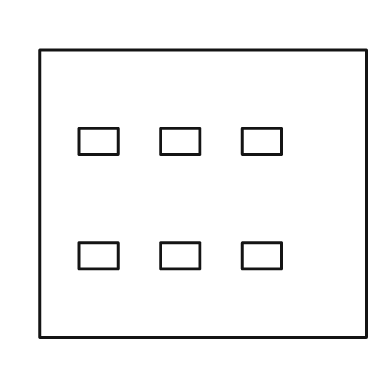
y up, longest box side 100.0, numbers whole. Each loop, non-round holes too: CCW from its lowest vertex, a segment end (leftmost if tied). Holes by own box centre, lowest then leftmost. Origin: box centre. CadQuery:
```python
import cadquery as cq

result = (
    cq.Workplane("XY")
    .moveTo(-50.0, -44.0)
    .lineTo(50.0, -44.0)
    .lineTo(50.0, 44.0)
    .lineTo(-50.0, 44.0)
    .close()
    .moveTo(-38.0, -23.0)
    .lineTo(-26.0, -23.0)
    .lineTo(-26.0, -15.0)
    .lineTo(-38.0, -15.0)
    .close()
    .moveTo(-13.0, -23.0)
    .lineTo(-1.0, -23.0)
    .lineTo(-1.0, -15.0)
    .lineTo(-13.0, -15.0)
    .close()
    .moveTo(12.0, -23.0)
    .lineTo(24.0, -23.0)
    .lineTo(24.0, -15.0)
    .lineTo(12.0, -15.0)
    .close()
    .moveTo(-38.0, 12.0)
    .lineTo(-26.0, 12.0)
    .lineTo(-26.0, 20.0)
    .lineTo(-38.0, 20.0)
    .close()
    .moveTo(-13.0, 12.0)
    .lineTo(-1.0, 12.0)
    .lineTo(-1.0, 20.0)
    .lineTo(-13.0, 20.0)
    .close()
    .moveTo(12.0, 12.0)
    .lineTo(24.0, 12.0)
    .lineTo(24.0, 20.0)
    .lineTo(12.0, 20.0)
    .close()
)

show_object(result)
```